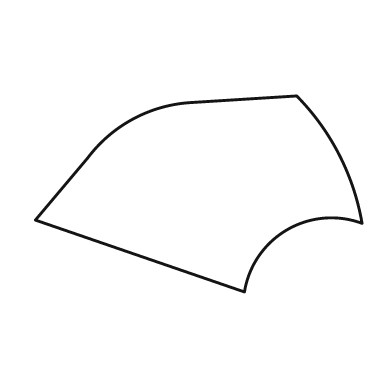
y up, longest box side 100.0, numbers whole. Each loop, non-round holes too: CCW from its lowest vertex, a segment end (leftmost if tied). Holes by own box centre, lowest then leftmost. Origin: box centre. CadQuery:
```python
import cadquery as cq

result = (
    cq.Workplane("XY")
    .moveTo(14.0, -30.0)
    .threePointArc((27.0, -11.0), (50.0, -9.0))
    .threePointArc((43.0, 12.0), (30.0, 30.0))
    .lineTo(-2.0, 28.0)
    .threePointArc((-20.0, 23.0), (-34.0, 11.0))
    .lineTo(-50.0, -8.0)
    .close()
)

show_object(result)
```